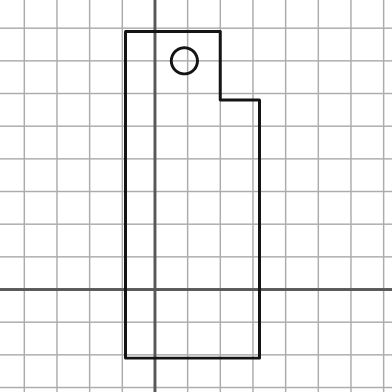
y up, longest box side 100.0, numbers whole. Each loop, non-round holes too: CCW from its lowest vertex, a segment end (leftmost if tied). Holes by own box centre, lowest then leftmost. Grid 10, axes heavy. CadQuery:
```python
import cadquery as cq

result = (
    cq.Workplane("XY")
    .moveTo(-9.0, -21.0)
    .lineTo(32.0, -21.0)
    .lineTo(32.0, 58.0)
    .lineTo(20.0, 58.0)
    .lineTo(20.0, 79.0)
    .lineTo(-9.0, 79.0)
    .close()
    .moveTo(9.0, 70.0)
    .circle(4.0)
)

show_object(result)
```